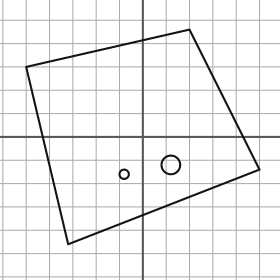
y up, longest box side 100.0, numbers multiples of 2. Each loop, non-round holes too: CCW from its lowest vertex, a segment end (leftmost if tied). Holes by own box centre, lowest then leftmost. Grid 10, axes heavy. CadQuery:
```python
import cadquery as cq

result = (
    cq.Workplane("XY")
    .moveTo(-32.0, -46.0)
    .lineTo(50.0, -14.0)
    .lineTo(20.0, 46.0)
    .lineTo(-50.0, 30.0)
    .close()
    .moveTo(-8.0, -16.0)
    .circle(2.0)
    .moveTo(12.0, -12.0)
    .circle(4.0)
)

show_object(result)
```